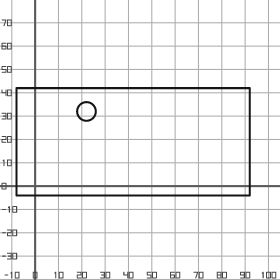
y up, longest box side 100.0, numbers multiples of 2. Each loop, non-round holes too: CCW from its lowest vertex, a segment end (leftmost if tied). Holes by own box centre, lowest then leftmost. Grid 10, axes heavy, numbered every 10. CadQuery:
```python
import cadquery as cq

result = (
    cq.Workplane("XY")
    .moveTo(-8.0, -4.0)
    .lineTo(92.0, -4.0)
    .lineTo(92.0, 42.0)
    .lineTo(-8.0, 42.0)
    .close()
    .moveTo(22.0, 32.0)
    .circle(4.0)
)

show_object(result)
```